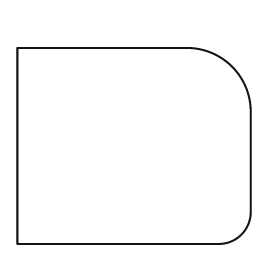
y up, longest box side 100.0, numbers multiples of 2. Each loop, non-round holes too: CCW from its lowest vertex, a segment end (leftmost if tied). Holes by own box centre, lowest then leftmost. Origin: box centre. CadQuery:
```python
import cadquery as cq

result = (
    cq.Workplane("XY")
    .moveTo(-50.0, -42.0)
    .lineTo(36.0, -42.0)
    .threePointArc((46.0, -38.0), (50.0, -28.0))
    .lineTo(50.0, 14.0)
    .threePointArc((42.0, 34.0), (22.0, 42.0))
    .lineTo(-50.0, 42.0)
    .close()
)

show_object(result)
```